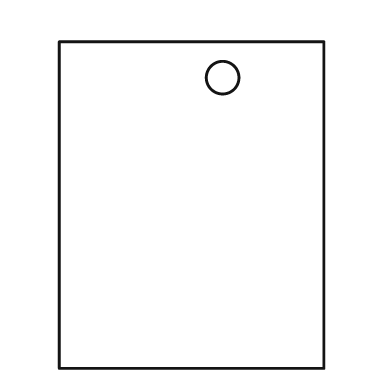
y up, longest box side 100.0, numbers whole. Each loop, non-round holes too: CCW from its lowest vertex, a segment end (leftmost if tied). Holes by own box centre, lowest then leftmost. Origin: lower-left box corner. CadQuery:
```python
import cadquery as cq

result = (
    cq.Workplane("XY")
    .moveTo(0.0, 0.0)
    .lineTo(81.0, 0.0)
    .lineTo(81.0, 100.0)
    .lineTo(0.0, 100.0)
    .close()
    .moveTo(50.0, 89.0)
    .circle(5.0)
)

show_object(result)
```